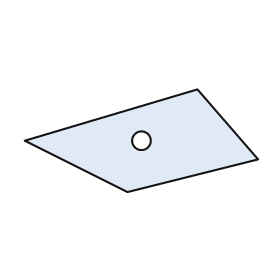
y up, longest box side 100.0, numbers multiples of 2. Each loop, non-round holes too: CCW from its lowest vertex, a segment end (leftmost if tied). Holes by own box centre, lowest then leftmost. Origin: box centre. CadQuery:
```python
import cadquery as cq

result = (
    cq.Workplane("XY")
    .moveTo(-6.0, -22.0)
    .lineTo(50.0, -8.0)
    .lineTo(24.0, 22.0)
    .lineTo(-50.0, 0.0)
    .close()
    .moveTo(0.0, 0.0)
    .circle(4.0)
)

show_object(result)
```